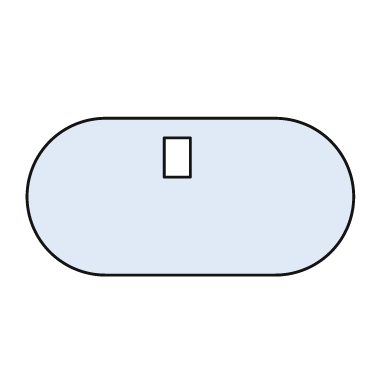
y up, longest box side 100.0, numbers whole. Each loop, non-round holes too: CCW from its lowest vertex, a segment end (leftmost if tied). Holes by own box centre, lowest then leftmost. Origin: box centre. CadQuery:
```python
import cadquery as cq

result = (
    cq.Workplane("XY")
    .moveTo(-26.0, -24.0)
    .lineTo(26.0, -24.0)
    .threePointArc((50.0, 0.0), (26.0, 24.0))
    .lineTo(-26.0, 24.0)
    .threePointArc((-50.0, 0.0), (-26.0, -24.0))
    .close()
    .moveTo(-8.0, 6.0)
    .lineTo(0.0, 6.0)
    .lineTo(0.0, 18.0)
    .lineTo(-8.0, 18.0)
    .close()
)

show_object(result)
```